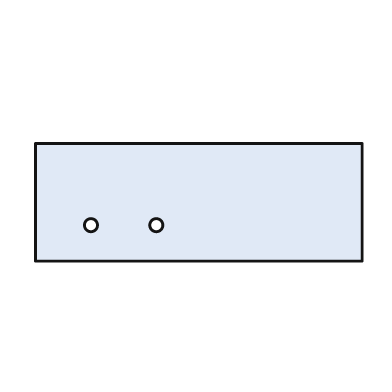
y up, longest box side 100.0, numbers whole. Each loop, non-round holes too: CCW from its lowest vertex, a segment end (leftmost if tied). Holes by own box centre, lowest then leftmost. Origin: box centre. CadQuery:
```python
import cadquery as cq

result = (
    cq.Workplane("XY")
    .moveTo(-50.0, -18.0)
    .lineTo(50.0, -18.0)
    .lineTo(50.0, 18.0)
    .lineTo(-50.0, 18.0)
    .close()
    .moveTo(-33.0, -7.0)
    .circle(2.0)
    .moveTo(-13.0, -7.0)
    .circle(2.0)
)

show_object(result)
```